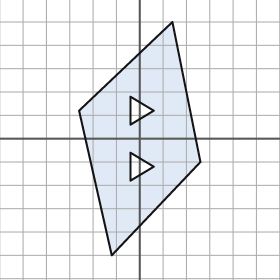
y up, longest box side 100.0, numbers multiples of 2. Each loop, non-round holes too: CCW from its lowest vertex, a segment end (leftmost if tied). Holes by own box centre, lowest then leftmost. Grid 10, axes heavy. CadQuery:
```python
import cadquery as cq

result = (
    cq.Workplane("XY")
    .moveTo(-12.0, -50.0)
    .lineTo(26.0, -10.0)
    .lineTo(14.0, 50.0)
    .lineTo(-26.0, 12.0)
    .close()
    .moveTo(-4.0, -18.0)
    .lineTo(6.0, -12.0)
    .lineTo(-4.0, -6.0)
    .close()
    .moveTo(-4.0, 6.0)
    .lineTo(6.0, 12.0)
    .lineTo(-4.0, 18.0)
    .close()
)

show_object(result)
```